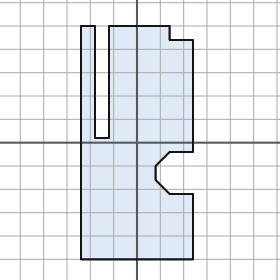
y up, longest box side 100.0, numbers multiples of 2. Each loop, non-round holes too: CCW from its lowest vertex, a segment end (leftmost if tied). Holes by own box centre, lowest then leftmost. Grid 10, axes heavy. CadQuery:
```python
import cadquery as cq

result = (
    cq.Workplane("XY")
    .moveTo(-24.0, -50.0)
    .lineTo(24.0, -50.0)
    .lineTo(24.0, -22.0)
    .lineTo(14.0, -22.0)
    .lineTo(8.0, -16.0)
    .lineTo(8.0, -10.0)
    .lineTo(14.0, -4.0)
    .lineTo(24.0, -4.0)
    .lineTo(24.0, 44.0)
    .lineTo(14.0, 44.0)
    .lineTo(14.0, 50.0)
    .lineTo(-12.0, 50.0)
    .lineTo(-12.0, 2.0)
    .lineTo(-18.0, 2.0)
    .lineTo(-18.0, 50.0)
    .lineTo(-24.0, 50.0)
    .close()
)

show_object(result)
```